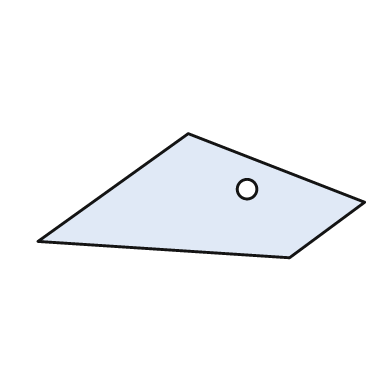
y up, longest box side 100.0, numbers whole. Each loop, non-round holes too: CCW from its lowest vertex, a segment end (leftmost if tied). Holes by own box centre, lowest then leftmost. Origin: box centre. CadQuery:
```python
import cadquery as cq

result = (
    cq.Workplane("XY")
    .moveTo(27.0, -19.0)
    .lineTo(50.0, -2.0)
    .lineTo(-4.0, 19.0)
    .lineTo(-50.0, -14.0)
    .close()
    .moveTo(14.0, 2.0)
    .circle(3.0)
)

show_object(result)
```